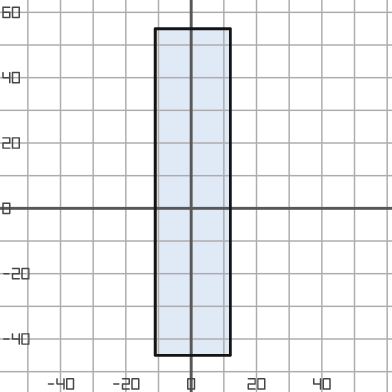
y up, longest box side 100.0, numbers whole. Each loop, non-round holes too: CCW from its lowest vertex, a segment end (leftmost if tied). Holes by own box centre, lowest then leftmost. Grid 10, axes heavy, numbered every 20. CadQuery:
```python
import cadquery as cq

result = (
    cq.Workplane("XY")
    .moveTo(-11.0, -45.0)
    .lineTo(12.0, -45.0)
    .lineTo(12.0, 55.0)
    .lineTo(-11.0, 55.0)
    .close()
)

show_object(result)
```